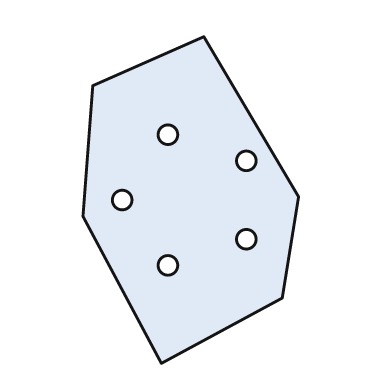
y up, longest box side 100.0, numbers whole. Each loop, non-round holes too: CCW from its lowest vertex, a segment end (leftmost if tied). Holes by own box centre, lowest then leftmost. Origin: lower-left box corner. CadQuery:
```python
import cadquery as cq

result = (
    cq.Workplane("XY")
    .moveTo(24.0, 0.0)
    .lineTo(61.0, 20.0)
    .lineTo(66.0, 51.0)
    .lineTo(37.0, 100.0)
    .lineTo(3.0, 85.0)
    .lineTo(0.0, 45.0)
    .close()
    .moveTo(26.0, 30.0)
    .circle(3.0)
    .moveTo(50.0, 38.0)
    .circle(3.0)
    .moveTo(12.0, 50.0)
    .circle(3.0)
    .moveTo(50.0, 62.0)
    .circle(3.0)
    .moveTo(26.0, 70.0)
    .circle(3.0)
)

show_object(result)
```